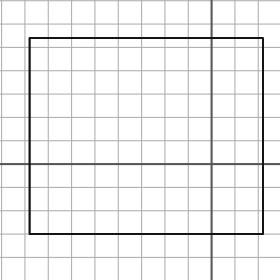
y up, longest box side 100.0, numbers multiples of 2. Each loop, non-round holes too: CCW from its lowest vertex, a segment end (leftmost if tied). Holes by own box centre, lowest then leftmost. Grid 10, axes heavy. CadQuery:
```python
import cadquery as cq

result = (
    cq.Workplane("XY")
    .moveTo(-78.0, -30.0)
    .lineTo(22.0, -30.0)
    .lineTo(22.0, 54.0)
    .lineTo(-78.0, 54.0)
    .close()
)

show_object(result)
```